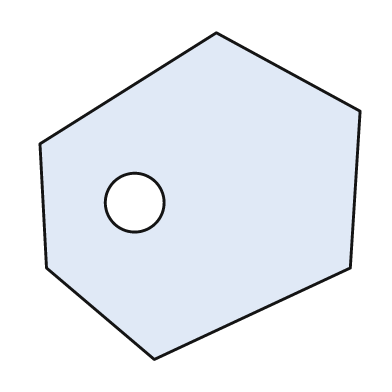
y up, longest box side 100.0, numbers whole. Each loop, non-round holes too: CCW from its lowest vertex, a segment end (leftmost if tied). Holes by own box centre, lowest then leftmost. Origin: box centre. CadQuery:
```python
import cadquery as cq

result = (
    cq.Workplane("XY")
    .moveTo(-14.0, -50.0)
    .lineTo(46.0, -22.0)
    .lineTo(49.0, 26.0)
    .lineTo(5.0, 50.0)
    .lineTo(-49.0, 16.0)
    .lineTo(-47.0, -22.0)
    .close()
    .moveTo(-20.0, -2.0)
    .circle(9.0)
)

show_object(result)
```